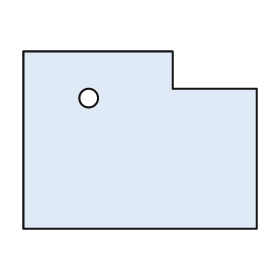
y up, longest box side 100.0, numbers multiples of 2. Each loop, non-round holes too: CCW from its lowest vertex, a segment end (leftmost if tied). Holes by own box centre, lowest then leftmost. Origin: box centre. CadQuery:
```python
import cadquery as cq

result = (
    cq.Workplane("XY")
    .moveTo(-50.0, -38.0)
    .lineTo(50.0, -38.0)
    .lineTo(50.0, 22.0)
    .lineTo(14.0, 22.0)
    .lineTo(14.0, 38.0)
    .lineTo(-50.0, 38.0)
    .close()
    .moveTo(-22.0, 18.0)
    .circle(4.0)
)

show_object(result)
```